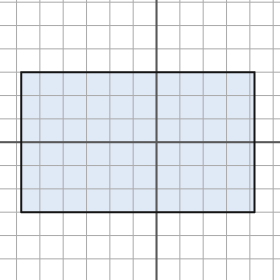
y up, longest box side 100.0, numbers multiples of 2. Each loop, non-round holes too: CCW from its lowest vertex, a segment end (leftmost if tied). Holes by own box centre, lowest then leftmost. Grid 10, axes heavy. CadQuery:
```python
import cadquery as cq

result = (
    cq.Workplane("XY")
    .moveTo(-58.0, -30.0)
    .lineTo(42.0, -30.0)
    .lineTo(42.0, 30.0)
    .lineTo(-58.0, 30.0)
    .close()
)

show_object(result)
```